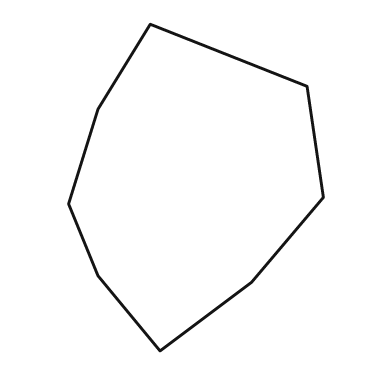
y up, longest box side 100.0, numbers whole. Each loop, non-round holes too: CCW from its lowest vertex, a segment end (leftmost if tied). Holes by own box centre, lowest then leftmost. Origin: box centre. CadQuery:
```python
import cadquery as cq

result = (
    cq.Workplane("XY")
    .moveTo(-11.0, -50.0)
    .lineTo(17.0, -29.0)
    .lineTo(39.0, -3.0)
    .lineTo(34.0, 31.0)
    .lineTo(-14.0, 50.0)
    .lineTo(-30.0, 24.0)
    .lineTo(-39.0, -5.0)
    .lineTo(-30.0, -27.0)
    .close()
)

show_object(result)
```